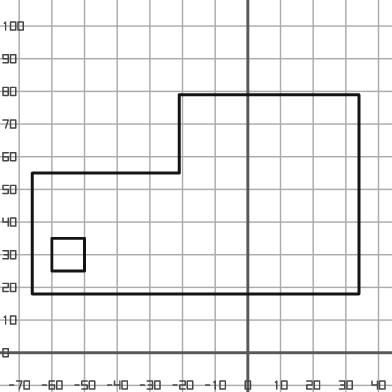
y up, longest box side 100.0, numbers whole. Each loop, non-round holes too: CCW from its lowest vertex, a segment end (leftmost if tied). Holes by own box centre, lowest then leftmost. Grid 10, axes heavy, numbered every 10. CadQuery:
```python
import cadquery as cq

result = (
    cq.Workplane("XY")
    .moveTo(-66.0, 18.0)
    .lineTo(34.0, 18.0)
    .lineTo(34.0, 79.0)
    .lineTo(-21.0, 79.0)
    .lineTo(-21.0, 55.0)
    .lineTo(-66.0, 55.0)
    .close()
    .moveTo(-60.0, 25.0)
    .lineTo(-50.0, 25.0)
    .lineTo(-50.0, 35.0)
    .lineTo(-60.0, 35.0)
    .close()
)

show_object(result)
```